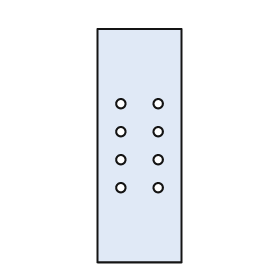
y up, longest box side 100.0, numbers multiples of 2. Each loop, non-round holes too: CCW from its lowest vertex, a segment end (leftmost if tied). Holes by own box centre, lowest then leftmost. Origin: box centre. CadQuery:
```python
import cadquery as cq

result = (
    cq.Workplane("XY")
    .moveTo(-18.0, -50.0)
    .lineTo(18.0, -50.0)
    .lineTo(18.0, 50.0)
    .lineTo(-18.0, 50.0)
    .close()
    .moveTo(-8.0, -18.0)
    .circle(2.0)
    .moveTo(8.0, -18.0)
    .circle(2.0)
    .moveTo(-8.0, -6.0)
    .circle(2.0)
    .moveTo(8.0, -6.0)
    .circle(2.0)
    .moveTo(-8.0, 6.0)
    .circle(2.0)
    .moveTo(8.0, 6.0)
    .circle(2.0)
    .moveTo(-8.0, 18.0)
    .circle(2.0)
    .moveTo(8.0, 18.0)
    .circle(2.0)
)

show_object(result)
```